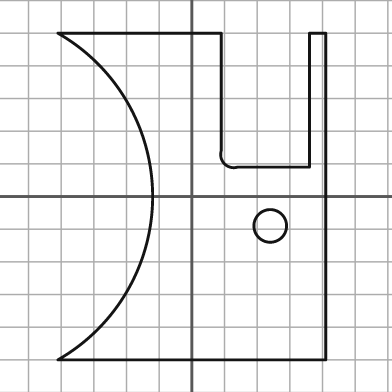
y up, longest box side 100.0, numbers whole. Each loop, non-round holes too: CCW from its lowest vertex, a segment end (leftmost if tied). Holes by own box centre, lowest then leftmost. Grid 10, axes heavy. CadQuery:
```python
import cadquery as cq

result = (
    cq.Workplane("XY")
    .moveTo(-41.0, -50.0)
    .lineTo(41.0, -50.0)
    .lineTo(41.0, 50.0)
    .lineTo(36.0, 50.0)
    .lineTo(36.0, 9.0)
    .lineTo(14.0, 9.0)
    .threePointArc((10.0, 10.0), (9.0, 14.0))
    .lineTo(9.0, 50.0)
    .lineTo(-41.0, 50.0)
    .threePointArc((-12.0, 0.0), (-41.0, -50.0))
    .close()
    .moveTo(24.0, -9.0)
    .circle(5.0)
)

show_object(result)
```